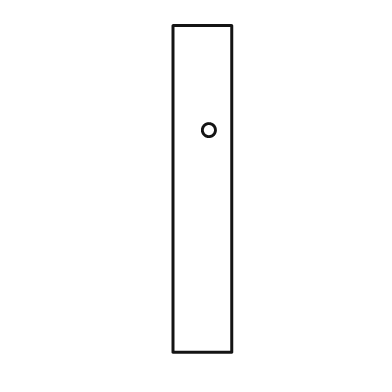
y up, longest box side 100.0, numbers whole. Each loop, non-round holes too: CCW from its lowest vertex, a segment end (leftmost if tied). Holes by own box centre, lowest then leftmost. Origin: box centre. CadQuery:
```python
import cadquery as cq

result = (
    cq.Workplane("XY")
    .moveTo(-9.0, -50.0)
    .lineTo(9.0, -50.0)
    .lineTo(9.0, 50.0)
    .lineTo(-9.0, 50.0)
    .close()
    .moveTo(2.0, 18.0)
    .circle(2.0)
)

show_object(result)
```